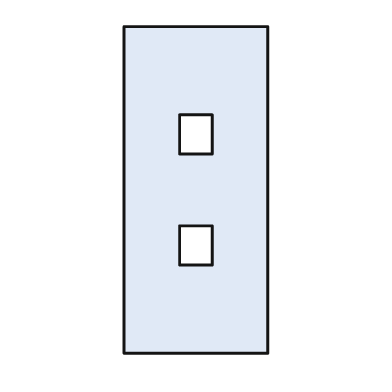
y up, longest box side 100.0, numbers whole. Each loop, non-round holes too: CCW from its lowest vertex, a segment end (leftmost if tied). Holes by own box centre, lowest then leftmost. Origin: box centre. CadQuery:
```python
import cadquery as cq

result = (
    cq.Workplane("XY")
    .moveTo(-22.0, -50.0)
    .lineTo(22.0, -50.0)
    .lineTo(22.0, 50.0)
    .lineTo(-22.0, 50.0)
    .close()
    .moveTo(-5.0, -23.0)
    .lineTo(5.0, -23.0)
    .lineTo(5.0, -11.0)
    .lineTo(-5.0, -11.0)
    .close()
    .moveTo(-5.0, 11.0)
    .lineTo(5.0, 11.0)
    .lineTo(5.0, 23.0)
    .lineTo(-5.0, 23.0)
    .close()
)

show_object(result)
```